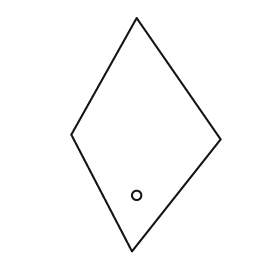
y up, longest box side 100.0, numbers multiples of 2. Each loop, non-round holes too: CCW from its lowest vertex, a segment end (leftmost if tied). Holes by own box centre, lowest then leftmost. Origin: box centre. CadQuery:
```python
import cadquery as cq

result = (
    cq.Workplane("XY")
    .moveTo(-6.0, -50.0)
    .lineTo(32.0, -2.0)
    .lineTo(-4.0, 50.0)
    .lineTo(-32.0, 0.0)
    .close()
    .moveTo(-4.0, -26.0)
    .circle(2.0)
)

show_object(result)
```